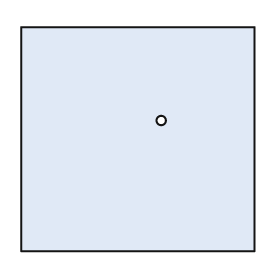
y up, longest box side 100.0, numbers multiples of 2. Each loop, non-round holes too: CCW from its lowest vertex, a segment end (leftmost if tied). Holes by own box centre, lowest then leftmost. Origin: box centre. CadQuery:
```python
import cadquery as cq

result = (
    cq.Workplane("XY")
    .moveTo(-50.0, -48.0)
    .lineTo(50.0, -48.0)
    .lineTo(50.0, 48.0)
    .lineTo(-50.0, 48.0)
    .close()
    .moveTo(10.0, 8.0)
    .circle(2.0)
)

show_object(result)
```